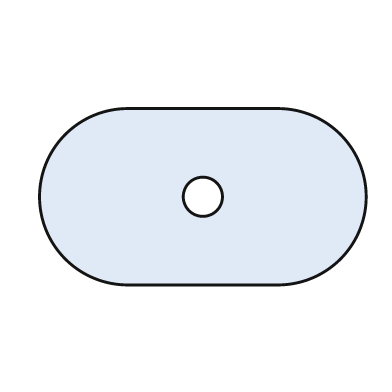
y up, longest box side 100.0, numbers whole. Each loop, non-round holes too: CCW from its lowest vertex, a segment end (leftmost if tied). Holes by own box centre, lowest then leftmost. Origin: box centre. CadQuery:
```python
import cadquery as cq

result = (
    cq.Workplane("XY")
    .moveTo(-23.0, -27.0)
    .lineTo(23.0, -27.0)
    .threePointArc((50.0, 0.0), (23.0, 27.0))
    .lineTo(-23.0, 27.0)
    .threePointArc((-50.0, 0.0), (-23.0, -27.0))
    .close()
    .moveTo(0.0, 0.0)
    .circle(6.0)
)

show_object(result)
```